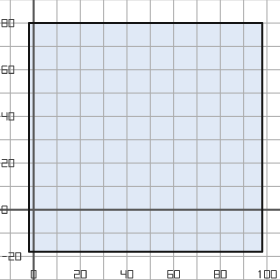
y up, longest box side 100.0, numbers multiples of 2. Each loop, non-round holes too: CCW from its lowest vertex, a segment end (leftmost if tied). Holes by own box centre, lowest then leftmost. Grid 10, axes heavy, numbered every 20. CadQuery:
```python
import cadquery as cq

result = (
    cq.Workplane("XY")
    .moveTo(-2.0, -18.0)
    .lineTo(98.0, -18.0)
    .lineTo(98.0, 80.0)
    .lineTo(-2.0, 80.0)
    .close()
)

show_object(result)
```